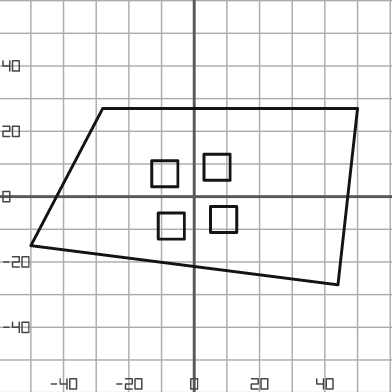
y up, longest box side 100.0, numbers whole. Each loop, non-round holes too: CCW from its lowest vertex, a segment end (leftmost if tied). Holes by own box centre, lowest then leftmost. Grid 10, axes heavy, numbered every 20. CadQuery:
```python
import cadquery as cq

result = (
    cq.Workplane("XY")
    .moveTo(44.0, -27.0)
    .lineTo(50.0, 27.0)
    .lineTo(-28.0, 27.0)
    .lineTo(-50.0, -15.0)
    .close()
    .moveTo(-11.0, -13.0)
    .lineTo(-3.0, -13.0)
    .lineTo(-3.0, -5.0)
    .lineTo(-11.0, -5.0)
    .close()
    .moveTo(5.0, -11.0)
    .lineTo(13.0, -11.0)
    .lineTo(13.0, -3.0)
    .lineTo(5.0, -3.0)
    .close()
    .moveTo(-13.0, 3.0)
    .lineTo(-5.0, 3.0)
    .lineTo(-5.0, 11.0)
    .lineTo(-13.0, 11.0)
    .close()
    .moveTo(3.0, 5.0)
    .lineTo(11.0, 5.0)
    .lineTo(11.0, 13.0)
    .lineTo(3.0, 13.0)
    .close()
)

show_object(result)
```